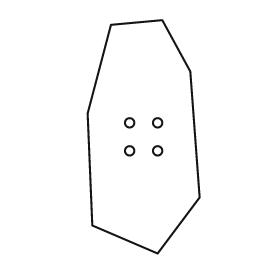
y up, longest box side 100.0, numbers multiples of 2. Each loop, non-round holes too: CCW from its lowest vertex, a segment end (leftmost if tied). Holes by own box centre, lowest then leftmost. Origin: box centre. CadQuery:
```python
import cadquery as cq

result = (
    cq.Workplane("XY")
    .moveTo(6.0, -50.0)
    .lineTo(24.0, -26.0)
    .lineTo(20.0, 28.0)
    .lineTo(8.0, 50.0)
    .lineTo(-14.0, 48.0)
    .lineTo(-24.0, 10.0)
    .lineTo(-22.0, -38.0)
    .close()
    .moveTo(-6.0, -6.0)
    .circle(2.0)
    .moveTo(6.0, -6.0)
    .circle(2.0)
    .moveTo(-6.0, 6.0)
    .circle(2.0)
    .moveTo(6.0, 6.0)
    .circle(2.0)
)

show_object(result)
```